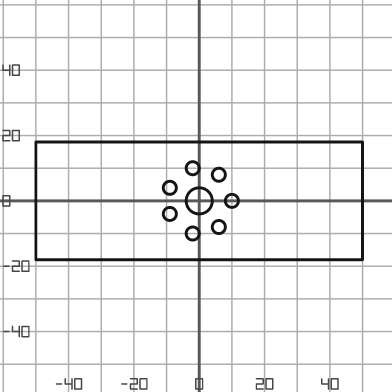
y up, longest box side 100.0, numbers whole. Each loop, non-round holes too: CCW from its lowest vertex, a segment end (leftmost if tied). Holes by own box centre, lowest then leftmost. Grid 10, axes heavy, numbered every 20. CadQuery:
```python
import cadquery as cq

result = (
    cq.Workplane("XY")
    .moveTo(-50.0, -18.0)
    .lineTo(50.0, -18.0)
    .lineTo(50.0, 18.0)
    .lineTo(-50.0, 18.0)
    .close()
    .moveTo(-2.0, -10.0)
    .circle(2.0)
    .moveTo(6.0, -8.0)
    .circle(2.0)
    .moveTo(-9.0, -4.0)
    .circle(2.0)
    .moveTo(0.0, 0.0)
    .circle(4.0)
    .moveTo(10.0, 0.0)
    .circle(2.0)
    .moveTo(-9.0, 4.0)
    .circle(2.0)
    .moveTo(6.0, 8.0)
    .circle(2.0)
    .moveTo(-2.0, 10.0)
    .circle(2.0)
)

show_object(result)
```